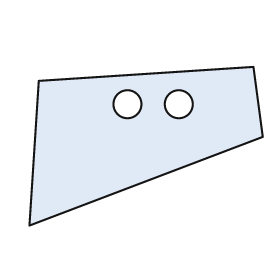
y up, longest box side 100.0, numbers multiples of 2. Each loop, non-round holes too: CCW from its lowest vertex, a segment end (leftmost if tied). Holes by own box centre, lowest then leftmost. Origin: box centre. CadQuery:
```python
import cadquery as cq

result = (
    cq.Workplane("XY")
    .moveTo(-50.0, -34.0)
    .lineTo(50.0, 4.0)
    .lineTo(46.0, 34.0)
    .lineTo(-46.0, 28.0)
    .close()
    .moveTo(-8.0, 18.0)
    .circle(6.0)
    .moveTo(14.0, 18.0)
    .circle(6.0)
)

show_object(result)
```